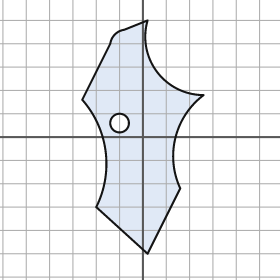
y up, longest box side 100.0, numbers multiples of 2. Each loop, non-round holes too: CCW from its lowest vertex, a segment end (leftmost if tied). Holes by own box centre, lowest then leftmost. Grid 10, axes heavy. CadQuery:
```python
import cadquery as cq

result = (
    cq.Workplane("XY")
    .moveTo(2.0, -50.0)
    .lineTo(16.0, -22.0)
    .threePointArc((14.0, 0.0), (26.0, 18.0))
    .threePointArc((6.0, 28.0), (2.0, 50.0))
    .lineTo(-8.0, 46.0)
    .threePointArc((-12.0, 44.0), (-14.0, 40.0))
    .lineTo(-26.0, 16.0)
    .threePointArc((-16.0, -6.0), (-20.0, -30.0))
    .close()
    .moveTo(-10.0, 6.0)
    .circle(4.0)
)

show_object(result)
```